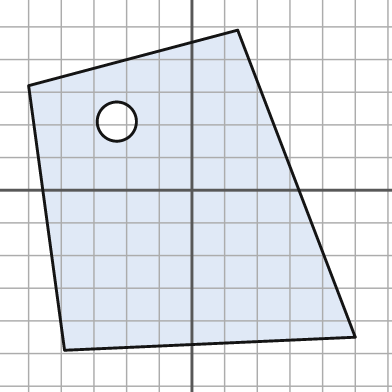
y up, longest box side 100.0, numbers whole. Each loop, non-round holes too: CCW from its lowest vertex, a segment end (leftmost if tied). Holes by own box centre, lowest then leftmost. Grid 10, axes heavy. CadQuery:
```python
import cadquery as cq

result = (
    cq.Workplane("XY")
    .moveTo(-39.0, -49.0)
    .lineTo(50.0, -45.0)
    .lineTo(14.0, 49.0)
    .lineTo(-50.0, 32.0)
    .close()
    .moveTo(-23.0, 21.0)
    .circle(6.0)
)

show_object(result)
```